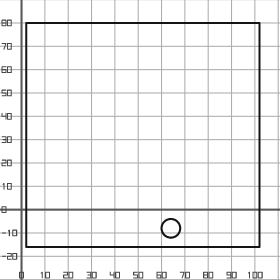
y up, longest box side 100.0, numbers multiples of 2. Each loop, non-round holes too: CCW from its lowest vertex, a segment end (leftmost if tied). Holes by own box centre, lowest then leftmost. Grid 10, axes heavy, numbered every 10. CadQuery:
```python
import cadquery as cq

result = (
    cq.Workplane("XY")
    .moveTo(2.0, -16.0)
    .lineTo(102.0, -16.0)
    .lineTo(102.0, 80.0)
    .lineTo(2.0, 80.0)
    .close()
    .moveTo(64.0, -8.0)
    .circle(4.0)
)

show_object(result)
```